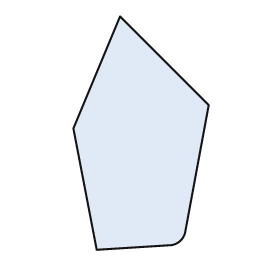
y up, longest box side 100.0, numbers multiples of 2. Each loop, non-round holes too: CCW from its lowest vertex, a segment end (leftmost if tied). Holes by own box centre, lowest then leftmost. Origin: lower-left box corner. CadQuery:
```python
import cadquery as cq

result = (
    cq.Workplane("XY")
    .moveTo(10.0, 0.0)
    .lineTo(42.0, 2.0)
    .threePointArc((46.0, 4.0), (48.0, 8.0))
    .lineTo(58.0, 62.0)
    .lineTo(20.0, 100.0)
    .lineTo(0.0, 52.0)
    .close()
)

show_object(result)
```